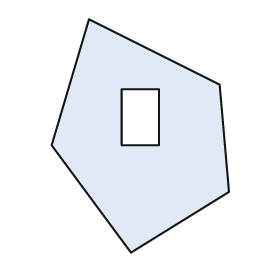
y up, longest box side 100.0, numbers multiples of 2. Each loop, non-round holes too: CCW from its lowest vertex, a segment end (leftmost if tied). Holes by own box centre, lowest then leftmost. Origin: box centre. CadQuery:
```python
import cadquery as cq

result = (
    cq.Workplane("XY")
    .moveTo(-4.0, -50.0)
    .lineTo(38.0, -24.0)
    .lineTo(34.0, 22.0)
    .lineTo(-22.0, 50.0)
    .lineTo(-38.0, -4.0)
    .close()
    .moveTo(-8.0, -4.0)
    .lineTo(8.0, -4.0)
    .lineTo(8.0, 20.0)
    .lineTo(-8.0, 20.0)
    .close()
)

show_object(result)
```